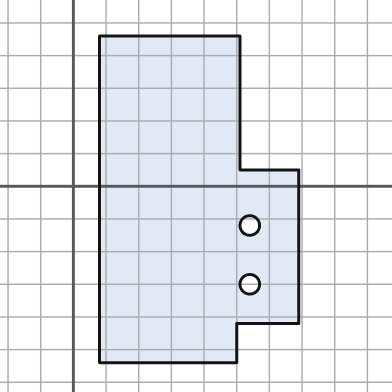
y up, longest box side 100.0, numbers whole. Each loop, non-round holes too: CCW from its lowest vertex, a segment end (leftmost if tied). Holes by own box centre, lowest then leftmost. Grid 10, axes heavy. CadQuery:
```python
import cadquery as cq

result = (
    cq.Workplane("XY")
    .moveTo(8.0, -54.0)
    .lineTo(50.0, -54.0)
    .lineTo(50.0, -42.0)
    .lineTo(69.0, -42.0)
    .lineTo(69.0, 5.0)
    .lineTo(51.0, 5.0)
    .lineTo(51.0, 46.0)
    .lineTo(8.0, 46.0)
    .close()
    .moveTo(54.0, -30.0)
    .circle(3.0)
    .moveTo(54.0, -12.0)
    .circle(3.0)
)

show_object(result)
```